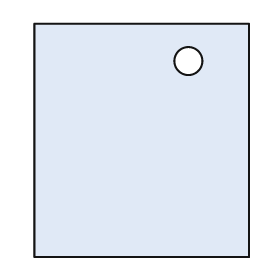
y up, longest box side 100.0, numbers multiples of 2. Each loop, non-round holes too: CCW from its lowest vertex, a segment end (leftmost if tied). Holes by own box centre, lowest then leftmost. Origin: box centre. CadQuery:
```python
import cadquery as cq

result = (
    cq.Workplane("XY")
    .moveTo(-46.0, -50.0)
    .lineTo(46.0, -50.0)
    .lineTo(46.0, 50.0)
    .lineTo(-46.0, 50.0)
    .close()
    .moveTo(20.0, 34.0)
    .circle(6.0)
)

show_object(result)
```